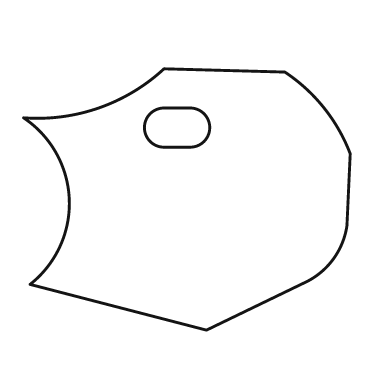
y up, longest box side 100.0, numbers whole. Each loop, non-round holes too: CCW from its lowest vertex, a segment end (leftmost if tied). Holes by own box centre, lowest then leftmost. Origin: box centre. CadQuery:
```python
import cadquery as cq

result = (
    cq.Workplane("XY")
    .moveTo(6.0, -40.0)
    .lineTo(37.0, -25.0)
    .threePointArc((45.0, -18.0), (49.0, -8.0))
    .lineTo(50.0, 14.0)
    .threePointArc((42.0, 28.0), (30.0, 39.0))
    .lineTo(-7.0, 40.0)
    .threePointArc((-27.0, 28.0), (-50.0, 25.0))
    .threePointArc((-36.0, 0.0), (-48.0, -26.0))
    .close()
    .moveTo(-7.0, 16.0)
    .lineTo(1.0, 16.0)
    .threePointArc((7.0, 22.0), (1.0, 28.0))
    .lineTo(-7.0, 28.0)
    .threePointArc((-13.0, 22.0), (-7.0, 16.0))
    .close()
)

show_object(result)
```